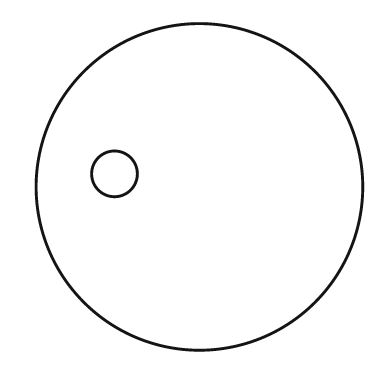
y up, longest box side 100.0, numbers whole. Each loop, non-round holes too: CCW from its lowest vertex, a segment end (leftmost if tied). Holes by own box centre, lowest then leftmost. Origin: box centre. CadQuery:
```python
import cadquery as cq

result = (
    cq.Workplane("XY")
    .moveTo(0.0, 0.0)
    .circle(50.0)
    .moveTo(-26.0, 4.0)
    .circle(7.0)
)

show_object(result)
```